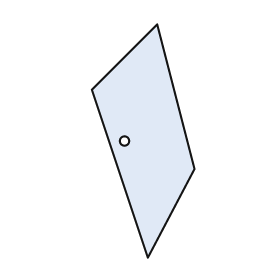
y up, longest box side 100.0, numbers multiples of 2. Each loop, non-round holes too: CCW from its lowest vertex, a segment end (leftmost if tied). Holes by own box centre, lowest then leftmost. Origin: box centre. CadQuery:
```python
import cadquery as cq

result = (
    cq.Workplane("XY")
    .moveTo(2.0, -50.0)
    .lineTo(22.0, -12.0)
    .lineTo(6.0, 50.0)
    .lineTo(-22.0, 22.0)
    .close()
    .moveTo(-8.0, 0.0)
    .circle(2.0)
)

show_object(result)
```